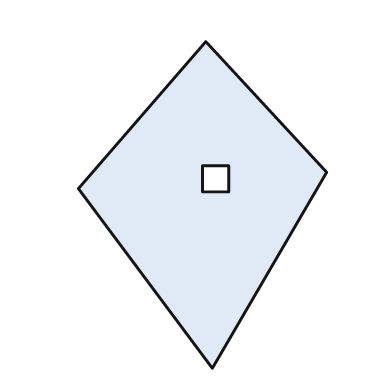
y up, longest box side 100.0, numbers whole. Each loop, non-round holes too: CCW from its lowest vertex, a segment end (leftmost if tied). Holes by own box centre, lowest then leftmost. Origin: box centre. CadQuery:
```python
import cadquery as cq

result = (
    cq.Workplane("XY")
    .moveTo(3.0, -50.0)
    .lineTo(38.0, 10.0)
    .lineTo(1.0, 50.0)
    .lineTo(-38.0, 5.0)
    .close()
    .moveTo(0.0, 4.0)
    .lineTo(8.0, 4.0)
    .lineTo(8.0, 12.0)
    .lineTo(0.0, 12.0)
    .close()
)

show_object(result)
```